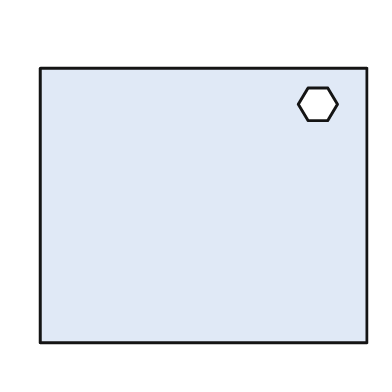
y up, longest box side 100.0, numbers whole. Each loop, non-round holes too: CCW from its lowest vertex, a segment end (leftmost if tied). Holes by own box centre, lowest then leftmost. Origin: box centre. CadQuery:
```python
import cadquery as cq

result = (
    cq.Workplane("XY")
    .moveTo(-50.0, -42.0)
    .lineTo(50.0, -42.0)
    .lineTo(50.0, 42.0)
    .lineTo(-50.0, 42.0)
    .close()
    .moveTo(32.0, 26.0)
    .lineTo(38.0, 26.0)
    .lineTo(41.0, 31.0)
    .lineTo(38.0, 36.0)
    .lineTo(32.0, 36.0)
    .lineTo(29.0, 31.0)
    .close()
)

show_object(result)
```